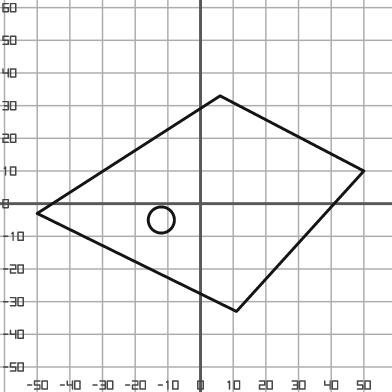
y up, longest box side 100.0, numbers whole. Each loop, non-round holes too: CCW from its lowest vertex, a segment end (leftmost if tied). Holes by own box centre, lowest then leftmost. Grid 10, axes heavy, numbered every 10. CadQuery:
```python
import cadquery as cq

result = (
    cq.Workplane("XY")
    .moveTo(11.0, -33.0)
    .lineTo(50.0, 10.0)
    .lineTo(6.0, 33.0)
    .lineTo(-50.0, -3.0)
    .close()
    .moveTo(-12.0, -5.0)
    .circle(4.0)
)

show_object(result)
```